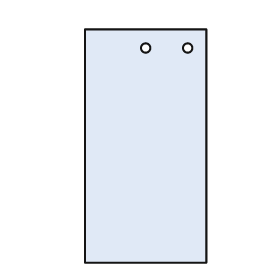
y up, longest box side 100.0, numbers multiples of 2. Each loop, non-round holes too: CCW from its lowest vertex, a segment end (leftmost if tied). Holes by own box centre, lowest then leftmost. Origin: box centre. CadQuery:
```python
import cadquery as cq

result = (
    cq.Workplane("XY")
    .moveTo(-26.0, -50.0)
    .lineTo(26.0, -50.0)
    .lineTo(26.0, 50.0)
    .lineTo(-26.0, 50.0)
    .close()
    .moveTo(0.0, 42.0)
    .circle(2.0)
    .moveTo(18.0, 42.0)
    .circle(2.0)
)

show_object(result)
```